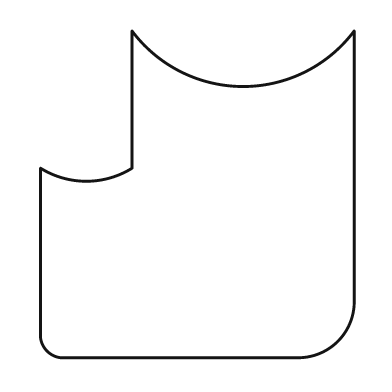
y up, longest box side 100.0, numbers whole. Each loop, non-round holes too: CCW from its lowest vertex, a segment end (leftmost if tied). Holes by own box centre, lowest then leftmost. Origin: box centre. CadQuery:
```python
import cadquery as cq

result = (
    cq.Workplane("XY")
    .moveTo(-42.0, -50.0)
    .lineTo(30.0, -50.0)
    .threePointArc((43.0, -45.0), (48.0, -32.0))
    .lineTo(48.0, 50.0)
    .threePointArc((14.0, 33.0), (-20.0, 50.0))
    .lineTo(-20.0, 8.0)
    .threePointArc((-34.0, 4.0), (-48.0, 8.0))
    .lineTo(-48.0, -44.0)
    .threePointArc((-46.0, -48.0), (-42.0, -50.0))
    .close()
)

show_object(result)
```